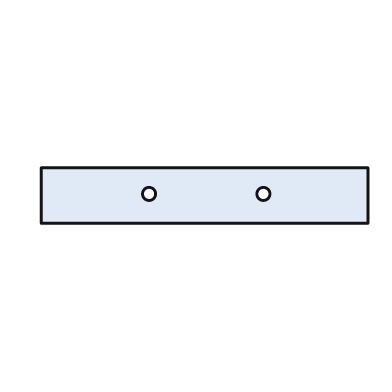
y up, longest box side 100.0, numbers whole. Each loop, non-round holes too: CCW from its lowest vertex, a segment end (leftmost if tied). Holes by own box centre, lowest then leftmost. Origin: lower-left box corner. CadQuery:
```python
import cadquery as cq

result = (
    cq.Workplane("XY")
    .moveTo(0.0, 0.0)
    .lineTo(100.0, 0.0)
    .lineTo(100.0, 17.0)
    .lineTo(0.0, 17.0)
    .close()
    .moveTo(33.0, 9.0)
    .circle(2.0)
    .moveTo(68.0, 9.0)
    .circle(2.0)
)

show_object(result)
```